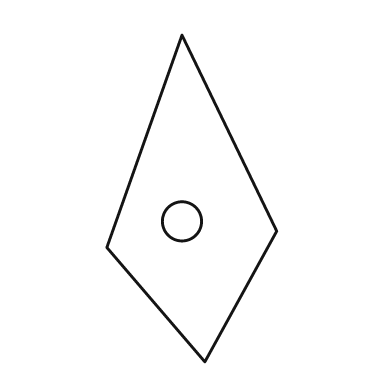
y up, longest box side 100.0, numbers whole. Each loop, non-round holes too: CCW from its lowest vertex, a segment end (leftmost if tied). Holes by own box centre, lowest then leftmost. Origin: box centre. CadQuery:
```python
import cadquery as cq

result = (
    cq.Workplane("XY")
    .moveTo(4.0, -50.0)
    .lineTo(26.0, -10.0)
    .lineTo(-3.0, 50.0)
    .lineTo(-26.0, -15.0)
    .close()
    .moveTo(-3.0, -7.0)
    .circle(6.0)
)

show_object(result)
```